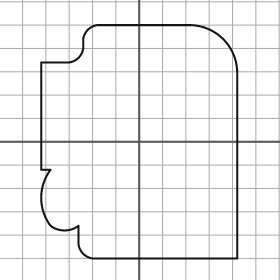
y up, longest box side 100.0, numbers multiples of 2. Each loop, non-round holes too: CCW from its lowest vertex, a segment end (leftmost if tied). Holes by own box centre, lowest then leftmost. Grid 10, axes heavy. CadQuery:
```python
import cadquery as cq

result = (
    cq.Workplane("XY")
    .moveTo(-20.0, -50.0)
    .lineTo(42.0, -50.0)
    .lineTo(42.0, 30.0)
    .threePointArc((36.0, 44.0), (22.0, 50.0))
    .lineTo(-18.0, 50.0)
    .threePointArc((-22.0, 48.0), (-24.0, 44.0))
    .lineTo(-24.0, 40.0)
    .threePointArc((-26.0, 36.0), (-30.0, 34.0))
    .lineTo(-42.0, 34.0)
    .lineTo(-42.0, -12.0)
    .lineTo(-38.0, -12.0)
    .threePointArc((-42.0, -24.0), (-38.0, -36.0))
    .threePointArc((-32.0, -38.0), (-26.0, -36.0))
    .lineTo(-26.0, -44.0)
    .threePointArc((-24.0, -48.0), (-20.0, -50.0))
    .close()
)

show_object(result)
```